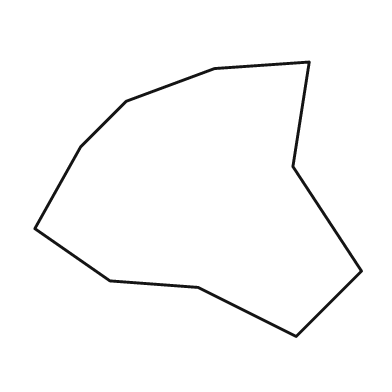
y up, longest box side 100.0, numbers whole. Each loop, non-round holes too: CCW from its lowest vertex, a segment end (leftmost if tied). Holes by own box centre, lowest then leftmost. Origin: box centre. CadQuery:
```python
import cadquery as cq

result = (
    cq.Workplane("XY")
    .moveTo(30.0, -42.0)
    .lineTo(50.0, -22.0)
    .lineTo(29.0, 10.0)
    .lineTo(34.0, 42.0)
    .lineTo(5.0, 40.0)
    .lineTo(-22.0, 30.0)
    .lineTo(-36.0, 16.0)
    .lineTo(-50.0, -9.0)
    .lineTo(-27.0, -25.0)
    .lineTo(0.0, -27.0)
    .close()
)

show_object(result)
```